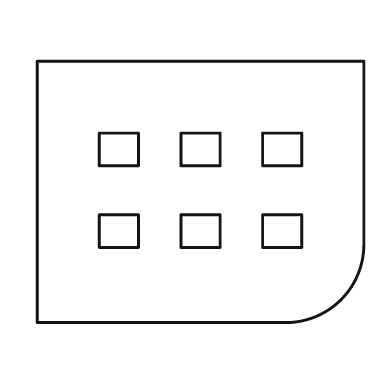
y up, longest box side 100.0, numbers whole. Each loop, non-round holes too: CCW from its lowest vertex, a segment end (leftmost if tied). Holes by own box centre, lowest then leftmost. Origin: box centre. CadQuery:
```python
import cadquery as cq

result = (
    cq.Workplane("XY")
    .moveTo(-50.0, -40.0)
    .lineTo(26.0, -40.0)
    .threePointArc((43.0, -33.0), (50.0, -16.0))
    .lineTo(50.0, 40.0)
    .lineTo(-50.0, 40.0)
    .close()
    .moveTo(-31.0, -17.0)
    .lineTo(-19.0, -17.0)
    .lineTo(-19.0, -7.0)
    .lineTo(-31.0, -7.0)
    .close()
    .moveTo(-6.0, -17.0)
    .lineTo(6.0, -17.0)
    .lineTo(6.0, -7.0)
    .lineTo(-6.0, -7.0)
    .close()
    .moveTo(19.0, -17.0)
    .lineTo(31.0, -17.0)
    .lineTo(31.0, -7.0)
    .lineTo(19.0, -7.0)
    .close()
    .moveTo(-31.0, 8.0)
    .lineTo(-19.0, 8.0)
    .lineTo(-19.0, 18.0)
    .lineTo(-31.0, 18.0)
    .close()
    .moveTo(-6.0, 8.0)
    .lineTo(6.0, 8.0)
    .lineTo(6.0, 18.0)
    .lineTo(-6.0, 18.0)
    .close()
    .moveTo(19.0, 8.0)
    .lineTo(31.0, 8.0)
    .lineTo(31.0, 18.0)
    .lineTo(19.0, 18.0)
    .close()
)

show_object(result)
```